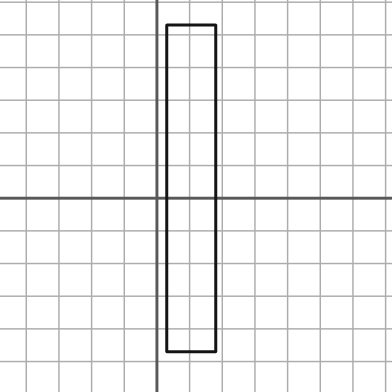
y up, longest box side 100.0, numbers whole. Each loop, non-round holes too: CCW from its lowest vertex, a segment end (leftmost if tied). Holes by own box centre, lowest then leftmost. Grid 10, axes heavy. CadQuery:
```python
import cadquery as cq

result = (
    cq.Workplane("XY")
    .moveTo(3.0, -47.0)
    .lineTo(18.0, -47.0)
    .lineTo(18.0, 53.0)
    .lineTo(3.0, 53.0)
    .close()
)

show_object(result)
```